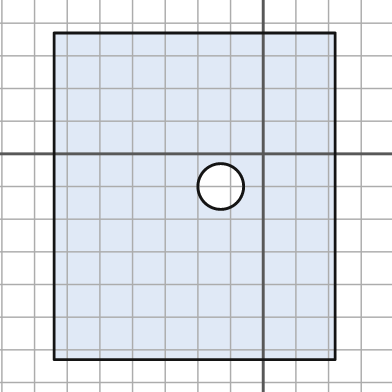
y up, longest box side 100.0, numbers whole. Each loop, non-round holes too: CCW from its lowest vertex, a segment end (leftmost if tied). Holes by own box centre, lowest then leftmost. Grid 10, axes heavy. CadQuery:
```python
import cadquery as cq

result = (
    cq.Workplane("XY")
    .moveTo(-64.0, -63.0)
    .lineTo(22.0, -63.0)
    .lineTo(22.0, 37.0)
    .lineTo(-64.0, 37.0)
    .close()
    .moveTo(-13.0, -10.0)
    .circle(7.0)
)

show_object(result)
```